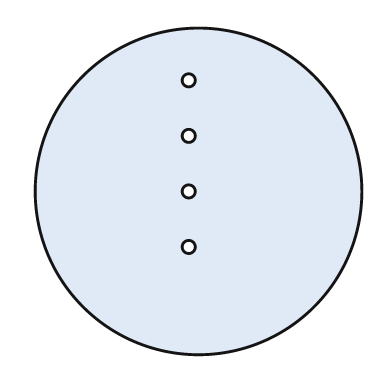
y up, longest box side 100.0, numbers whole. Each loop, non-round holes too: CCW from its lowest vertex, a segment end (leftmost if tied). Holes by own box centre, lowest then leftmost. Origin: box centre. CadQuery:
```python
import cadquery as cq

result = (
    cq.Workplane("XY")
    .moveTo(0.0, 0.0)
    .circle(50.0)
    .moveTo(-3.0, -17.0)
    .circle(2.0)
    .moveTo(-3.0, 0.0)
    .circle(2.0)
    .moveTo(-3.0, 17.0)
    .circle(2.0)
    .moveTo(-3.0, 34.0)
    .circle(2.0)
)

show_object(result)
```